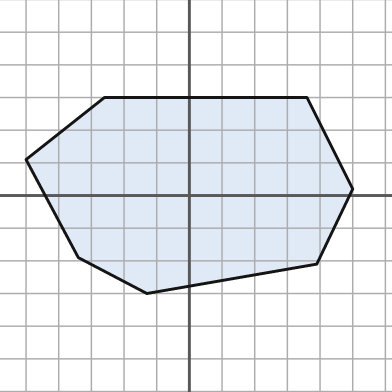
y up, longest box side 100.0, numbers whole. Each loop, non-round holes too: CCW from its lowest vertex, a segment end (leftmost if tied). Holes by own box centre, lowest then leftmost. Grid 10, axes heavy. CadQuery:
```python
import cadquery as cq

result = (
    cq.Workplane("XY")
    .moveTo(-13.0, -30.0)
    .lineTo(39.0, -21.0)
    .lineTo(50.0, 2.0)
    .lineTo(36.0, 30.0)
    .lineTo(-26.0, 30.0)
    .lineTo(-50.0, 11.0)
    .lineTo(-34.0, -19.0)
    .close()
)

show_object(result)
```